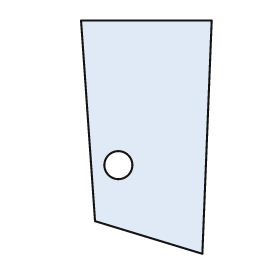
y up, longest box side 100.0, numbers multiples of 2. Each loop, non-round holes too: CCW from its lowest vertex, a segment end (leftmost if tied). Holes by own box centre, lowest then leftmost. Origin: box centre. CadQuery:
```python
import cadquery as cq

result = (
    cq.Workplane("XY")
    .moveTo(24.0, -50.0)
    .lineTo(28.0, 50.0)
    .lineTo(-28.0, 50.0)
    .lineTo(-22.0, -36.0)
    .close()
    .moveTo(-12.0, -12.0)
    .circle(6.0)
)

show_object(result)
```